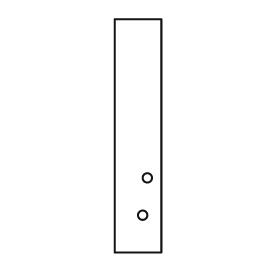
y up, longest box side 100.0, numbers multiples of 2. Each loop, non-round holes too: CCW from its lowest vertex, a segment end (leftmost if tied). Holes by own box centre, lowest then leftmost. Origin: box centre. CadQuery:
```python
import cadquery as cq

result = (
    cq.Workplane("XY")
    .moveTo(-10.0, -50.0)
    .lineTo(10.0, -50.0)
    .lineTo(10.0, 50.0)
    .lineTo(-10.0, 50.0)
    .close()
    .moveTo(2.0, -34.0)
    .circle(2.0)
    .moveTo(4.0, -18.0)
    .circle(2.0)
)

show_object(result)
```